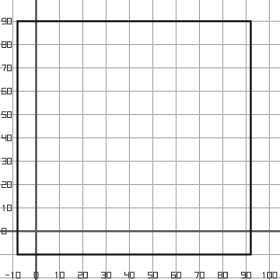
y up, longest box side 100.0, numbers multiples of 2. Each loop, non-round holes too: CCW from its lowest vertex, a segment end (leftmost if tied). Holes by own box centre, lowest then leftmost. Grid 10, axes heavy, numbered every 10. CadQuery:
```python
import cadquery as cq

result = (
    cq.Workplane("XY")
    .moveTo(-8.0, -10.0)
    .lineTo(92.0, -10.0)
    .lineTo(92.0, 90.0)
    .lineTo(-8.0, 90.0)
    .close()
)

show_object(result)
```